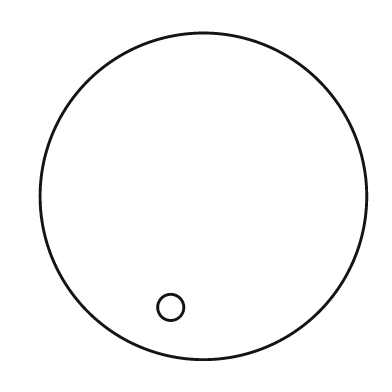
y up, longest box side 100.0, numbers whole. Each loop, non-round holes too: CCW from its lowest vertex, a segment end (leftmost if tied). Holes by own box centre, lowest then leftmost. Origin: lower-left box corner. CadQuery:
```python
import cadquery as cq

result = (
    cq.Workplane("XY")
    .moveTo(50.0, 50.0)
    .circle(50.0)
    .moveTo(40.0, 16.0)
    .circle(4.0)
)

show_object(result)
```